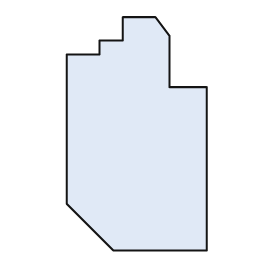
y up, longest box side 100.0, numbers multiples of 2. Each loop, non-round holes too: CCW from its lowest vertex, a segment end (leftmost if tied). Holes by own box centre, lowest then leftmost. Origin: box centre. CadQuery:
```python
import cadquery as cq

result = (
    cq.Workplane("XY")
    .moveTo(-10.0, -50.0)
    .lineTo(30.0, -50.0)
    .lineTo(30.0, 20.0)
    .lineTo(14.0, 20.0)
    .lineTo(14.0, 42.0)
    .lineTo(8.0, 50.0)
    .lineTo(-6.0, 50.0)
    .lineTo(-6.0, 40.0)
    .lineTo(-16.0, 40.0)
    .lineTo(-16.0, 34.0)
    .lineTo(-30.0, 34.0)
    .lineTo(-30.0, -30.0)
    .close()
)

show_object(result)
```